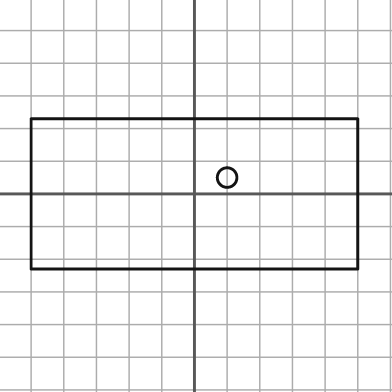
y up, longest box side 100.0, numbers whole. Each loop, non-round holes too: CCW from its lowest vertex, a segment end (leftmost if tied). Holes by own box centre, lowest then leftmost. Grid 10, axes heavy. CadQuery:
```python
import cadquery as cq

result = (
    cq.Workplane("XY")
    .moveTo(-50.0, -23.0)
    .lineTo(50.0, -23.0)
    .lineTo(50.0, 23.0)
    .lineTo(-50.0, 23.0)
    .close()
    .moveTo(10.0, 5.0)
    .circle(3.0)
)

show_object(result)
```